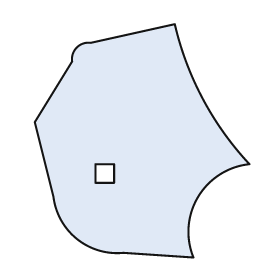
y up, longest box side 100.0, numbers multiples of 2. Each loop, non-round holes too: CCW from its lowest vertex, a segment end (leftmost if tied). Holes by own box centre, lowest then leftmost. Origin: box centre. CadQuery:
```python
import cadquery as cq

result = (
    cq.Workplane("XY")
    .moveTo(22.0, -50.0)
    .threePointArc((24.0, -24.0), (46.0, -10.0))
    .threePointArc((26.0, 18.0), (14.0, 50.0))
    .lineTo(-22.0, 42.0)
    .threePointArc((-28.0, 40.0), (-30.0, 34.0))
    .lineTo(-46.0, 8.0)
    .lineTo(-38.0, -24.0)
    .threePointArc((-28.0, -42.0), (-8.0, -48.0))
    .close()
    .moveTo(-20.0, -18.0)
    .lineTo(-12.0, -18.0)
    .lineTo(-12.0, -10.0)
    .lineTo(-20.0, -10.0)
    .close()
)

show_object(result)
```